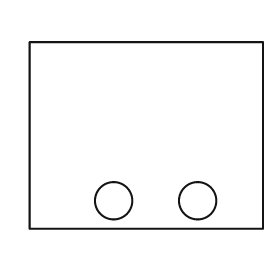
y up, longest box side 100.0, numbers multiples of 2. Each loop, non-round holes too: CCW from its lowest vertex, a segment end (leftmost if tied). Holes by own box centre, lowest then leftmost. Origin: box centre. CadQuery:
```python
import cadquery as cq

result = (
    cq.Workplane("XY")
    .moveTo(-50.0, -40.0)
    .lineTo(50.0, -40.0)
    .lineTo(50.0, 40.0)
    .lineTo(-50.0, 40.0)
    .close()
    .moveTo(-14.0, -28.0)
    .circle(8.0)
    .moveTo(22.0, -28.0)
    .circle(8.0)
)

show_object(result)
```